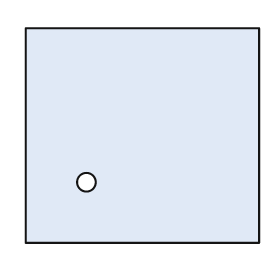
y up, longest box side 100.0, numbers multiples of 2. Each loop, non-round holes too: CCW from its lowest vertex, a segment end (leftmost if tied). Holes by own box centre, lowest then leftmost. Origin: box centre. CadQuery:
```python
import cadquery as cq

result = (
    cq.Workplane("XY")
    .moveTo(-50.0, -46.0)
    .lineTo(50.0, -46.0)
    .lineTo(50.0, 46.0)
    .lineTo(-50.0, 46.0)
    .close()
    .moveTo(-24.0, -20.0)
    .circle(4.0)
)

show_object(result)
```